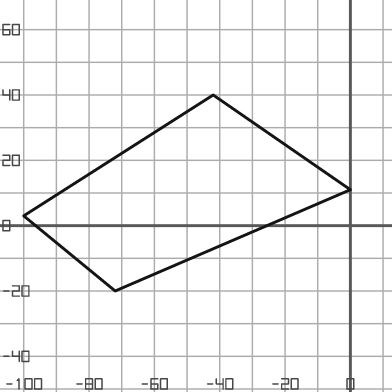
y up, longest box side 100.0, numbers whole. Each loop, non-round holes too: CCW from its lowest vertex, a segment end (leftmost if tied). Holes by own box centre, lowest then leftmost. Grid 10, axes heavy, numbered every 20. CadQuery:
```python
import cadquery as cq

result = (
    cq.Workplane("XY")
    .moveTo(-72.0, -20.0)
    .lineTo(0.0, 11.0)
    .lineTo(-42.0, 40.0)
    .lineTo(-100.0, 3.0)
    .close()
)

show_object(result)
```